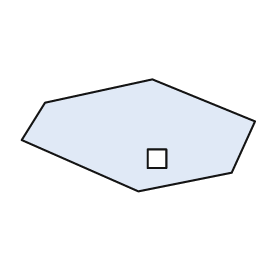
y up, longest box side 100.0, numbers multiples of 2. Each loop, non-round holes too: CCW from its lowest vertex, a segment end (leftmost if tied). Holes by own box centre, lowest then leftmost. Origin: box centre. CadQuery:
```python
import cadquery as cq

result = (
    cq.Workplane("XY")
    .moveTo(0.0, -24.0)
    .lineTo(40.0, -16.0)
    .lineTo(50.0, 6.0)
    .lineTo(6.0, 24.0)
    .lineTo(-40.0, 14.0)
    .lineTo(-50.0, -2.0)
    .close()
    .moveTo(4.0, -14.0)
    .lineTo(12.0, -14.0)
    .lineTo(12.0, -6.0)
    .lineTo(4.0, -6.0)
    .close()
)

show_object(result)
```